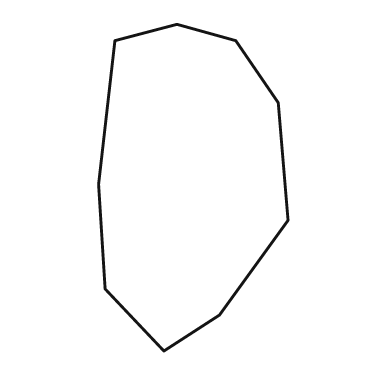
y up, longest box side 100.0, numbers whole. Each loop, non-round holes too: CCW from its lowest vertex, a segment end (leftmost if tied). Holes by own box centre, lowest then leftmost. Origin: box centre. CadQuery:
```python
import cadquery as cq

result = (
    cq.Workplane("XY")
    .moveTo(-9.0, -50.0)
    .lineTo(8.0, -39.0)
    .lineTo(29.0, -10.0)
    .lineTo(26.0, 26.0)
    .lineTo(13.0, 45.0)
    .lineTo(-5.0, 50.0)
    .lineTo(-24.0, 45.0)
    .lineTo(-29.0, 1.0)
    .lineTo(-27.0, -31.0)
    .close()
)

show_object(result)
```